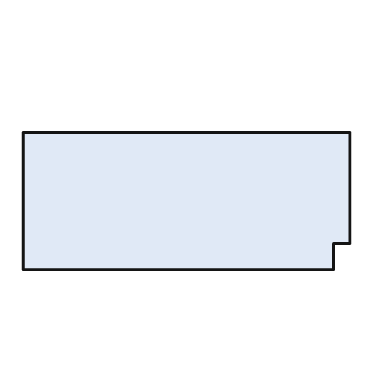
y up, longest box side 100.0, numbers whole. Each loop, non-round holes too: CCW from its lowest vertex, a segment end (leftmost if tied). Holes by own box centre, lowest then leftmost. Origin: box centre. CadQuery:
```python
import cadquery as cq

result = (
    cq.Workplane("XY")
    .moveTo(-50.0, -21.0)
    .lineTo(45.0, -21.0)
    .lineTo(45.0, -13.0)
    .lineTo(50.0, -13.0)
    .lineTo(50.0, 21.0)
    .lineTo(-50.0, 21.0)
    .close()
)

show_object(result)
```